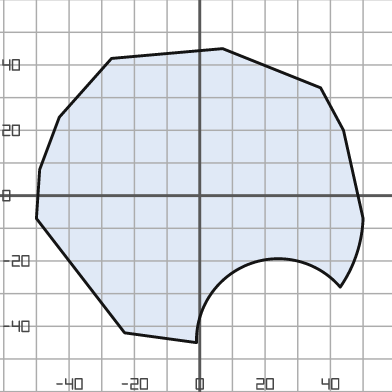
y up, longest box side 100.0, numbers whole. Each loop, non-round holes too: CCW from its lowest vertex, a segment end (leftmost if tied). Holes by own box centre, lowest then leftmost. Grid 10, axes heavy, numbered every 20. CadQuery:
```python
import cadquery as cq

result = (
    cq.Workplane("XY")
    .moveTo(-1.0, -45.0)
    .threePointArc((15.0, -21.0), (43.0, -28.0))
    .threePointArc((48.0, -18.0), (50.0, -7.0))
    .lineTo(44.0, 20.0)
    .lineTo(37.0, 33.0)
    .lineTo(7.0, 45.0)
    .lineTo(-27.0, 42.0)
    .lineTo(-43.0, 24.0)
    .lineTo(-49.0, 8.0)
    .lineTo(-50.0, -7.0)
    .lineTo(-23.0, -42.0)
    .close()
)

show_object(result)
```